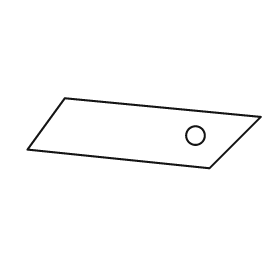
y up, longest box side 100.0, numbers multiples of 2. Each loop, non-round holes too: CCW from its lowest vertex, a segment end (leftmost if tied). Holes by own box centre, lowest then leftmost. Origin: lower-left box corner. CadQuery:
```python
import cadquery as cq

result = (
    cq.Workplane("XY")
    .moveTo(78.0, 0.0)
    .lineTo(100.0, 22.0)
    .lineTo(16.0, 30.0)
    .lineTo(0.0, 8.0)
    .close()
    .moveTo(72.0, 14.0)
    .circle(4.0)
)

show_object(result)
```